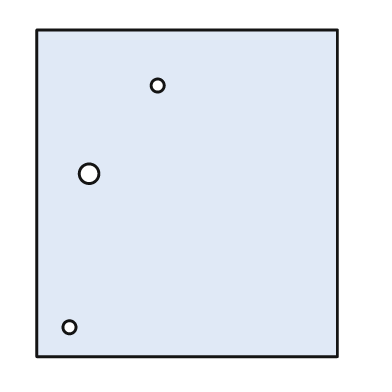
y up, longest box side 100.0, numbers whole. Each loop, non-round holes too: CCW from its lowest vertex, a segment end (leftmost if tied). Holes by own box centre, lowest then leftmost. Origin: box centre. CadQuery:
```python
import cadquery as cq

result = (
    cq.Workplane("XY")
    .moveTo(-46.0, -50.0)
    .lineTo(46.0, -50.0)
    .lineTo(46.0, 50.0)
    .lineTo(-46.0, 50.0)
    .close()
    .moveTo(-36.0, -41.0)
    .circle(2.0)
    .moveTo(-30.0, 6.0)
    .circle(3.0)
    .moveTo(-9.0, 33.0)
    .circle(2.0)
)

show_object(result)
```